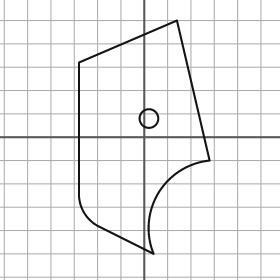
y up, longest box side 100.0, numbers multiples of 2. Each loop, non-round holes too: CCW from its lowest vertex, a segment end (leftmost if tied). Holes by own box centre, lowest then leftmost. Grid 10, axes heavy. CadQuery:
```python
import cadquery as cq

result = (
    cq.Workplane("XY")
    .moveTo(4.0, -50.0)
    .threePointArc((6.0, -24.0), (28.0, -10.0))
    .lineTo(14.0, 50.0)
    .lineTo(-28.0, 32.0)
    .lineTo(-28.0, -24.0)
    .threePointArc((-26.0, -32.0), (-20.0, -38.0))
    .close()
    .moveTo(2.0, 8.0)
    .circle(4.0)
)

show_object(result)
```